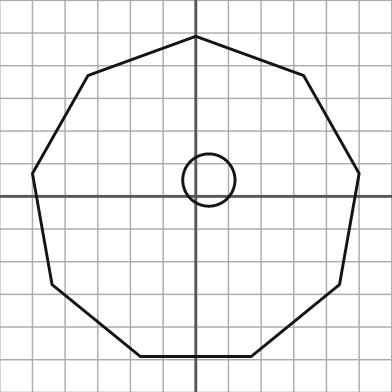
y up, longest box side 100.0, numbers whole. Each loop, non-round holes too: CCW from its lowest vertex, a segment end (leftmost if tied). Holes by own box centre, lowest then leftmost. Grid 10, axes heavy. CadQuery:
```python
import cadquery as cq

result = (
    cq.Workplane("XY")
    .moveTo(-17.0, -49.0)
    .lineTo(17.0, -49.0)
    .lineTo(44.0, -27.0)
    .lineTo(50.0, 7.0)
    .lineTo(33.0, 37.0)
    .lineTo(0.0, 49.0)
    .lineTo(-33.0, 37.0)
    .lineTo(-50.0, 7.0)
    .lineTo(-44.0, -27.0)
    .close()
    .moveTo(4.0, 5.0)
    .circle(8.0)
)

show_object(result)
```